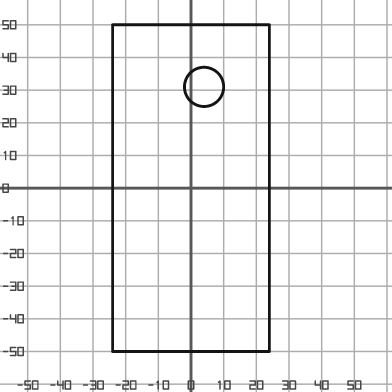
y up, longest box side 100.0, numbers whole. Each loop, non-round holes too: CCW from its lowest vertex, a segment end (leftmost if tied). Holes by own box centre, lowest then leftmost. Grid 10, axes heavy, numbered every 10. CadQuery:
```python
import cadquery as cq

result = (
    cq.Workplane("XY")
    .moveTo(-24.0, -50.0)
    .lineTo(24.0, -50.0)
    .lineTo(24.0, 50.0)
    .lineTo(-24.0, 50.0)
    .close()
    .moveTo(4.0, 31.0)
    .circle(6.0)
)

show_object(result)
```